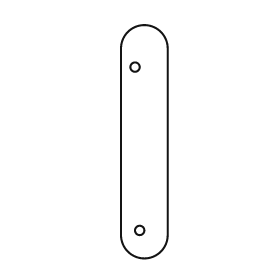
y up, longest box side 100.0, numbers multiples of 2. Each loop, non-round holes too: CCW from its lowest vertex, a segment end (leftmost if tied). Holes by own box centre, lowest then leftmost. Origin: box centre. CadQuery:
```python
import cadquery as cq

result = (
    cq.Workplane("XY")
    .moveTo(-10.0, -40.0)
    .threePointArc((0.0, -50.0), (10.0, -40.0))
    .lineTo(10.0, 40.0)
    .threePointArc((0.0, 50.0), (-10.0, 40.0))
    .close()
    .moveTo(-2.0, -38.0)
    .circle(2.0)
    .moveTo(-4.0, 32.0)
    .circle(2.0)
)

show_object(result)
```